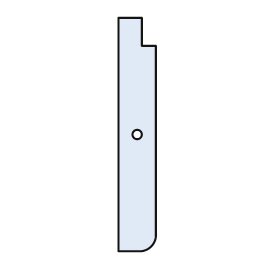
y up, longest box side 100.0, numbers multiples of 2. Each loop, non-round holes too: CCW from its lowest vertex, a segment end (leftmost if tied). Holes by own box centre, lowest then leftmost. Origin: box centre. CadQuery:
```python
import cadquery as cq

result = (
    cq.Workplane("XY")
    .moveTo(-8.0, -50.0)
    .lineTo(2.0, -50.0)
    .threePointArc((6.0, -48.0), (8.0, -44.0))
    .lineTo(8.0, 38.0)
    .lineTo(2.0, 38.0)
    .lineTo(2.0, 50.0)
    .lineTo(-8.0, 50.0)
    .close()
    .moveTo(0.0, 0.0)
    .circle(2.0)
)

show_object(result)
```